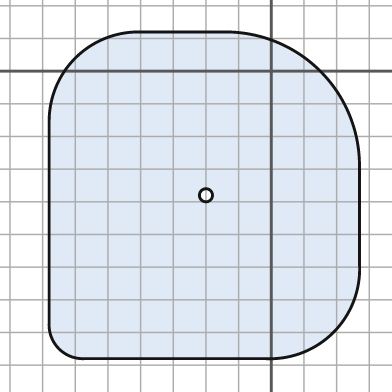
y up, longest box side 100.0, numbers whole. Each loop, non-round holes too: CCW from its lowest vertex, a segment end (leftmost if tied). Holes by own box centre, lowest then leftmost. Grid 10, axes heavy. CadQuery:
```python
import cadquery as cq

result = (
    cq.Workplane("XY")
    .moveTo(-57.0, -88.0)
    .lineTo(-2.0, -88.0)
    .threePointArc((19.0, -80.0), (27.0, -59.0))
    .lineTo(27.0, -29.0)
    .threePointArc((15.0, 0.0), (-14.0, 12.0))
    .lineTo(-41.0, 12.0)
    .threePointArc((-60.0, 4.0), (-68.0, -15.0))
    .lineTo(-68.0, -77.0)
    .threePointArc((-65.0, -85.0), (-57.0, -88.0))
    .close()
    .moveTo(-20.0, -38.0)
    .circle(2.0)
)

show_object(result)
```